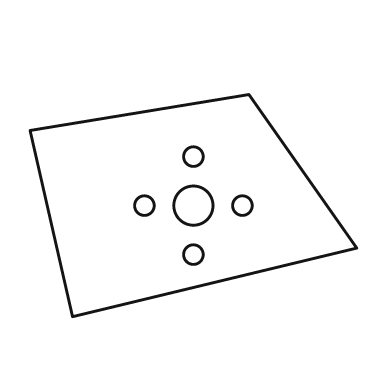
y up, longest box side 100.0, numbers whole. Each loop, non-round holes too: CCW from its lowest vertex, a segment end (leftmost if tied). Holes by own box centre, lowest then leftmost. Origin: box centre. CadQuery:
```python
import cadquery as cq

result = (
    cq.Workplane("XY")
    .moveTo(-37.0, -34.0)
    .lineTo(50.0, -13.0)
    .lineTo(17.0, 34.0)
    .lineTo(-50.0, 23.0)
    .close()
    .moveTo(0.0, -15.0)
    .circle(3.0)
    .moveTo(-15.0, 0.0)
    .circle(3.0)
    .moveTo(0.0, 0.0)
    .circle(6.0)
    .moveTo(15.0, 0.0)
    .circle(3.0)
    .moveTo(0.0, 15.0)
    .circle(3.0)
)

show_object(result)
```